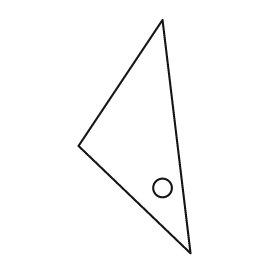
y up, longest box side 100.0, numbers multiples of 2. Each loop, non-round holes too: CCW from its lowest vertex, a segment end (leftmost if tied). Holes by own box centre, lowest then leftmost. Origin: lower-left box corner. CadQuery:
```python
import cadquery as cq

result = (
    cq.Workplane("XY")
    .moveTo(48.0, 0.0)
    .lineTo(36.0, 100.0)
    .lineTo(0.0, 46.0)
    .close()
    .moveTo(36.0, 28.0)
    .circle(4.0)
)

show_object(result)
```